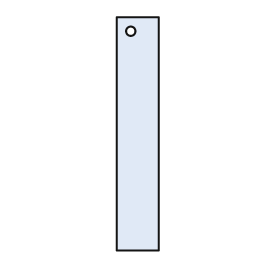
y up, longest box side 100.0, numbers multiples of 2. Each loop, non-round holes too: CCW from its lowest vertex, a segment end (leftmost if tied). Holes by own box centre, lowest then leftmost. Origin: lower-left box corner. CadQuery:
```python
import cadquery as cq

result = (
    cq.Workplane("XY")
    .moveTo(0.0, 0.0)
    .lineTo(18.0, 0.0)
    .lineTo(18.0, 100.0)
    .lineTo(0.0, 100.0)
    .close()
    .moveTo(6.0, 94.0)
    .circle(2.0)
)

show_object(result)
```